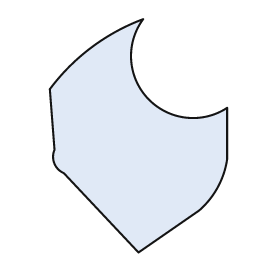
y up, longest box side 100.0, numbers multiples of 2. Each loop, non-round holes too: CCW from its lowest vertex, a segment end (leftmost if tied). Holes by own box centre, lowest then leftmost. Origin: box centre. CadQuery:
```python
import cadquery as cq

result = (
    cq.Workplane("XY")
    .moveTo(0.0, -50.0)
    .lineTo(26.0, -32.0)
    .threePointArc((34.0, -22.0), (38.0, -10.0))
    .lineTo(38.0, 12.0)
    .threePointArc((4.0, 16.0), (2.0, 50.0))
    .threePointArc((-20.0, 38.0), (-38.0, 20.0))
    .lineTo(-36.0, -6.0)
    .threePointArc((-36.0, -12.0), (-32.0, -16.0))
    .close()
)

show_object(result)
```